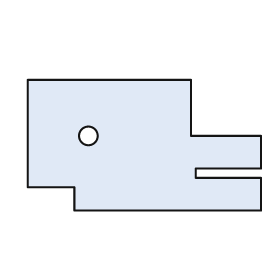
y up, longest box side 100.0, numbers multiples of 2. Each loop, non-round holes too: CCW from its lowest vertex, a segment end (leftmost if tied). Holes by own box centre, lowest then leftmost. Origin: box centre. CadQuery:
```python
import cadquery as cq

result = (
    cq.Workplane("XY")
    .moveTo(-30.0, -28.0)
    .lineTo(50.0, -28.0)
    .lineTo(50.0, -14.0)
    .lineTo(22.0, -14.0)
    .lineTo(22.0, -10.0)
    .lineTo(50.0, -10.0)
    .lineTo(50.0, 4.0)
    .lineTo(20.0, 4.0)
    .lineTo(20.0, 28.0)
    .lineTo(-50.0, 28.0)
    .lineTo(-50.0, -18.0)
    .lineTo(-30.0, -18.0)
    .close()
    .moveTo(-24.0, 4.0)
    .circle(4.0)
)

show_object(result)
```